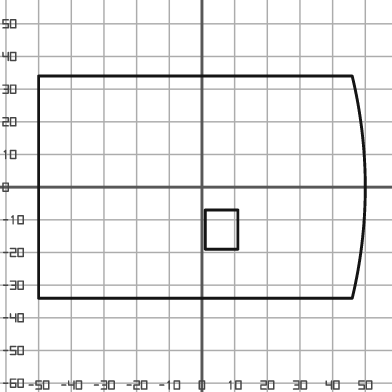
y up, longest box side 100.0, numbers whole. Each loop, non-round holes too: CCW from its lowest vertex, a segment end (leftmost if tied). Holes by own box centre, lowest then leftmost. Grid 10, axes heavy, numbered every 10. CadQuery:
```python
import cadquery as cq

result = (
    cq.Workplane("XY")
    .moveTo(-50.0, -34.0)
    .lineTo(46.0, -34.0)
    .threePointArc((50.0, 0.0), (46.0, 34.0))
    .lineTo(-50.0, 34.0)
    .close()
    .moveTo(1.0, -19.0)
    .lineTo(11.0, -19.0)
    .lineTo(11.0, -7.0)
    .lineTo(1.0, -7.0)
    .close()
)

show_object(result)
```